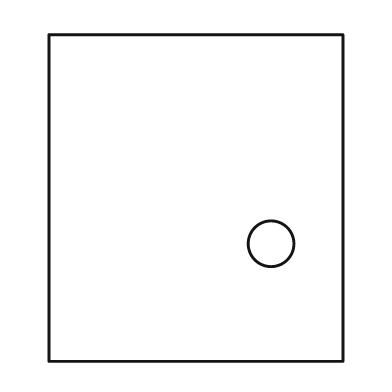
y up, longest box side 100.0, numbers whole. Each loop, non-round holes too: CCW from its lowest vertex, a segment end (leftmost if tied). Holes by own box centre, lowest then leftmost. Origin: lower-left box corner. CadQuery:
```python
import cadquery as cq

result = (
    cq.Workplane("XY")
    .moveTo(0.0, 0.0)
    .lineTo(90.0, 0.0)
    .lineTo(90.0, 100.0)
    .lineTo(0.0, 100.0)
    .close()
    .moveTo(68.0, 36.0)
    .circle(7.0)
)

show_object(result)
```